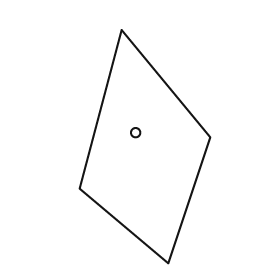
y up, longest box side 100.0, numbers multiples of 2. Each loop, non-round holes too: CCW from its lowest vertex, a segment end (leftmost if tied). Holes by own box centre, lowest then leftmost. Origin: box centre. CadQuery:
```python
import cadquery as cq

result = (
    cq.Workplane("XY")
    .moveTo(10.0, -50.0)
    .lineTo(28.0, 4.0)
    .lineTo(-10.0, 50.0)
    .lineTo(-28.0, -18.0)
    .close()
    .moveTo(-4.0, 6.0)
    .circle(2.0)
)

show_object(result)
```